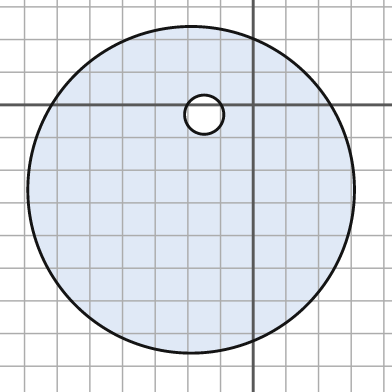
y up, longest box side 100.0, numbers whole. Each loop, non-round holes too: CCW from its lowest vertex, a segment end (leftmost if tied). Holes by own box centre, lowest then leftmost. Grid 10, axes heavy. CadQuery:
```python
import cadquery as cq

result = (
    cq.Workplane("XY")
    .moveTo(-19.0, -26.0)
    .circle(50.0)
    .moveTo(-15.0, -3.0)
    .circle(6.0)
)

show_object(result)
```